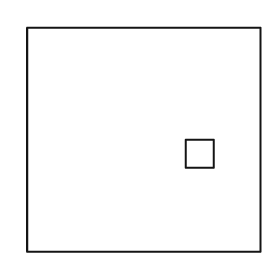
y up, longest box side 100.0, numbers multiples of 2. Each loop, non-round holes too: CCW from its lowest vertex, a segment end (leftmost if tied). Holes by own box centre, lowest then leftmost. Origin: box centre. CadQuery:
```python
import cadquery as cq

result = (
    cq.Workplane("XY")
    .moveTo(-50.0, -48.0)
    .lineTo(50.0, -48.0)
    .lineTo(50.0, 48.0)
    .lineTo(-50.0, 48.0)
    .close()
    .moveTo(18.0, -12.0)
    .lineTo(30.0, -12.0)
    .lineTo(30.0, 0.0)
    .lineTo(18.0, 0.0)
    .close()
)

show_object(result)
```